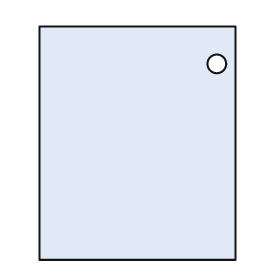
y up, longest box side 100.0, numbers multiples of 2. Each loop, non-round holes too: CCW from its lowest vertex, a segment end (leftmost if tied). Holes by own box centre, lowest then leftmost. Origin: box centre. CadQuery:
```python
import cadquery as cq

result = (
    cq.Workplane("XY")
    .moveTo(-42.0, -50.0)
    .lineTo(42.0, -50.0)
    .lineTo(42.0, 50.0)
    .lineTo(-42.0, 50.0)
    .close()
    .moveTo(34.0, 34.0)
    .circle(4.0)
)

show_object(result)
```